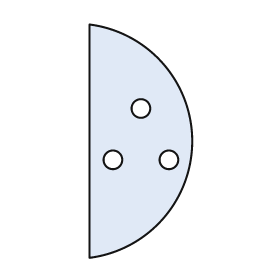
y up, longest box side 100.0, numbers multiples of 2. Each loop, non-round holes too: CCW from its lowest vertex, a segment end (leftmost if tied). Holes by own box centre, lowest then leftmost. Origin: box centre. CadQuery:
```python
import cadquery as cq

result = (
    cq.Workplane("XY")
    .moveTo(-22.0, -50.0)
    .threePointArc((22.0, 0.0), (-22.0, 50.0))
    .close()
    .moveTo(-12.0, -8.0)
    .circle(4.0)
    .moveTo(12.0, -8.0)
    .circle(4.0)
    .moveTo(0.0, 14.0)
    .circle(4.0)
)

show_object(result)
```